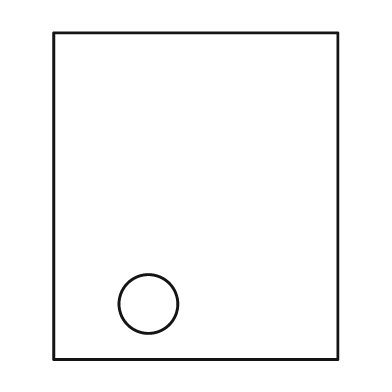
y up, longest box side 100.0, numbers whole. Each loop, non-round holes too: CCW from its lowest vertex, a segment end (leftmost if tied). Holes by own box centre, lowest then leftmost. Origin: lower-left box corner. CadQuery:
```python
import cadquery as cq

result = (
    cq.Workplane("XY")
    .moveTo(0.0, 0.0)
    .lineTo(87.0, 0.0)
    .lineTo(87.0, 100.0)
    .lineTo(0.0, 100.0)
    .close()
    .moveTo(29.0, 17.0)
    .circle(9.0)
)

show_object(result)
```